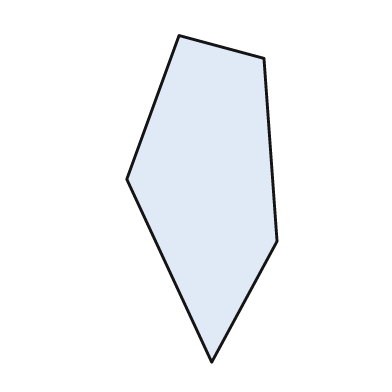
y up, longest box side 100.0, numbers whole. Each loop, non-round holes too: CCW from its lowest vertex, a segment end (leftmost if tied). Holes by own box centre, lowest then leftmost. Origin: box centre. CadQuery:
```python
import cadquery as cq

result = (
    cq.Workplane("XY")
    .moveTo(3.0, -50.0)
    .lineTo(23.0, -13.0)
    .lineTo(19.0, 43.0)
    .lineTo(-7.0, 50.0)
    .lineTo(-23.0, 6.0)
    .close()
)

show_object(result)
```